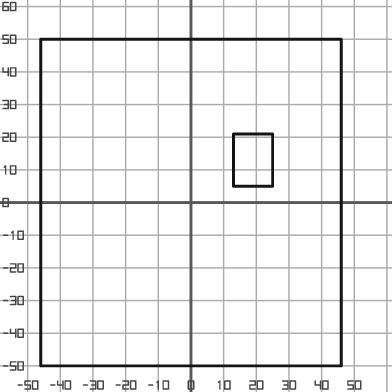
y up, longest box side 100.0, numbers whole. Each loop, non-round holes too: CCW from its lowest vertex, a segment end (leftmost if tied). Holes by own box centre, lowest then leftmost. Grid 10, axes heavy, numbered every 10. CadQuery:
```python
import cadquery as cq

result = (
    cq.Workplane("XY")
    .moveTo(-46.0, -50.0)
    .lineTo(46.0, -50.0)
    .lineTo(46.0, 50.0)
    .lineTo(-46.0, 50.0)
    .close()
    .moveTo(13.0, 5.0)
    .lineTo(25.0, 5.0)
    .lineTo(25.0, 21.0)
    .lineTo(13.0, 21.0)
    .close()
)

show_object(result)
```